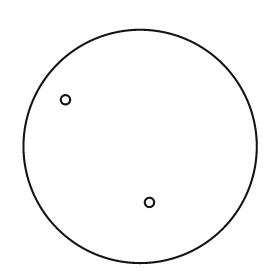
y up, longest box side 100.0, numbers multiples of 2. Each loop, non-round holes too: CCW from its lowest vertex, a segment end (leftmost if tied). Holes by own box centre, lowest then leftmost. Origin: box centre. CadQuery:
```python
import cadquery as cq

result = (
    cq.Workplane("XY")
    .moveTo(0.0, 0.0)
    .circle(50.0)
    .moveTo(4.0, -24.0)
    .circle(2.0)
    .moveTo(-32.0, 20.0)
    .circle(2.0)
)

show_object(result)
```